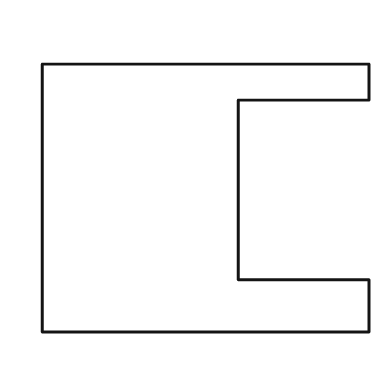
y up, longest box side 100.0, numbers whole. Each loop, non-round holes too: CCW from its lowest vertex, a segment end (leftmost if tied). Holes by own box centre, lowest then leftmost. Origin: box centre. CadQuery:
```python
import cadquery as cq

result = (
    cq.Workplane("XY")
    .moveTo(-50.0, -41.0)
    .lineTo(50.0, -41.0)
    .lineTo(50.0, -25.0)
    .lineTo(10.0, -25.0)
    .lineTo(10.0, 30.0)
    .lineTo(50.0, 30.0)
    .lineTo(50.0, 41.0)
    .lineTo(-50.0, 41.0)
    .close()
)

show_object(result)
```